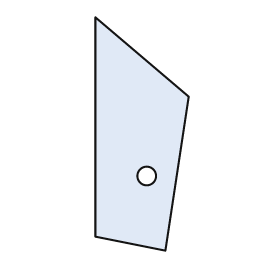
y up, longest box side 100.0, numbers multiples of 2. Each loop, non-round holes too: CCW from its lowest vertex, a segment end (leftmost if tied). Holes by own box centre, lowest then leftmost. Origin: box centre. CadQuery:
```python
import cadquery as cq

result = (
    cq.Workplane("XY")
    .moveTo(10.0, -50.0)
    .lineTo(20.0, 16.0)
    .lineTo(-20.0, 50.0)
    .lineTo(-20.0, -44.0)
    .close()
    .moveTo(2.0, -18.0)
    .circle(4.0)
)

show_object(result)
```